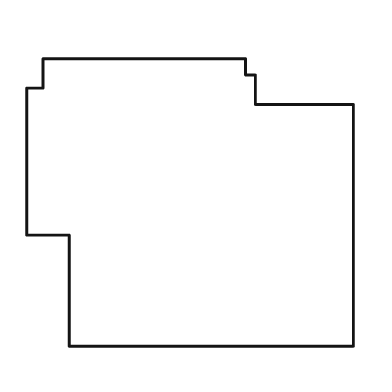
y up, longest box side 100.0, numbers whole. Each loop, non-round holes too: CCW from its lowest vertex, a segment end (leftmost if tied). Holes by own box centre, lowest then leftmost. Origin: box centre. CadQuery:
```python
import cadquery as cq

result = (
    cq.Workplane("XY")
    .moveTo(-37.0, -44.0)
    .lineTo(50.0, -44.0)
    .lineTo(50.0, 30.0)
    .lineTo(20.0, 30.0)
    .lineTo(20.0, 39.0)
    .lineTo(17.0, 39.0)
    .lineTo(17.0, 44.0)
    .lineTo(-45.0, 44.0)
    .lineTo(-45.0, 35.0)
    .lineTo(-50.0, 35.0)
    .lineTo(-50.0, -10.0)
    .lineTo(-37.0, -10.0)
    .close()
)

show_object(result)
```